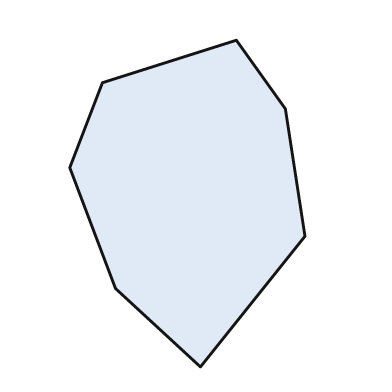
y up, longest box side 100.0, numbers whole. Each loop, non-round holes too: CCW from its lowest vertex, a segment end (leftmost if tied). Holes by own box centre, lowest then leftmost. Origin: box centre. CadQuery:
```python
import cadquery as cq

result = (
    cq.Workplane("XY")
    .moveTo(4.0, -50.0)
    .lineTo(36.0, -10.0)
    .lineTo(30.0, 29.0)
    .lineTo(15.0, 50.0)
    .lineTo(-26.0, 37.0)
    .lineTo(-36.0, 11.0)
    .lineTo(-22.0, -26.0)
    .close()
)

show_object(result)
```